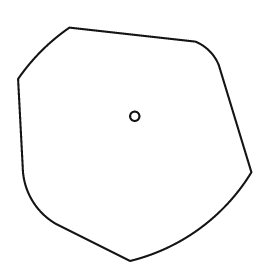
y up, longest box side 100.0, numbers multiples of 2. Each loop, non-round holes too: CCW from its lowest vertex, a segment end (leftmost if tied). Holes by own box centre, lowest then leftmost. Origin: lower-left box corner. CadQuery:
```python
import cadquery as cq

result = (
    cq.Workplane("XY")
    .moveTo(48.0, 0.0)
    .threePointArc((78.0, 14.0), (100.0, 38.0))
    .lineTo(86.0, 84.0)
    .threePointArc((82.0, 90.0), (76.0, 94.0))
    .lineTo(22.0, 100.0)
    .threePointArc((10.0, 90.0), (0.0, 78.0))
    .lineTo(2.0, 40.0)
    .threePointArc((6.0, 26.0), (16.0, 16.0))
    .close()
    .moveTo(50.0, 62.0)
    .circle(2.0)
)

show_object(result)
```